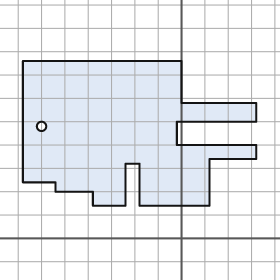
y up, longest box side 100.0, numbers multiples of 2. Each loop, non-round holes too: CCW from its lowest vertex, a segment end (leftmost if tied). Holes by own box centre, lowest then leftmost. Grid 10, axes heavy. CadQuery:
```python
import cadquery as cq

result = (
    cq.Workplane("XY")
    .moveTo(-38.0, 14.0)
    .lineTo(-24.0, 14.0)
    .lineTo(-24.0, 32.0)
    .lineTo(-18.0, 32.0)
    .lineTo(-18.0, 14.0)
    .lineTo(12.0, 14.0)
    .lineTo(12.0, 34.0)
    .lineTo(32.0, 34.0)
    .lineTo(32.0, 40.0)
    .lineTo(-2.0, 40.0)
    .lineTo(-2.0, 50.0)
    .lineTo(32.0, 50.0)
    .lineTo(32.0, 58.0)
    .lineTo(0.0, 58.0)
    .lineTo(0.0, 76.0)
    .lineTo(-68.0, 76.0)
    .lineTo(-68.0, 24.0)
    .lineTo(-54.0, 24.0)
    .lineTo(-54.0, 20.0)
    .lineTo(-38.0, 20.0)
    .close()
    .moveTo(-60.0, 48.0)
    .circle(2.0)
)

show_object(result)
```